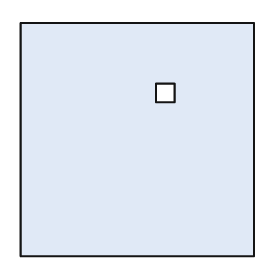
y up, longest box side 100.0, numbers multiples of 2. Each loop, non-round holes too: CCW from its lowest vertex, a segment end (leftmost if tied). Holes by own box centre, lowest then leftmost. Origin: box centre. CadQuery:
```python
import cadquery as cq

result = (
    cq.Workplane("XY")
    .moveTo(-50.0, -50.0)
    .lineTo(50.0, -50.0)
    .lineTo(50.0, 50.0)
    .lineTo(-50.0, 50.0)
    .close()
    .moveTo(8.0, 16.0)
    .lineTo(16.0, 16.0)
    .lineTo(16.0, 24.0)
    .lineTo(8.0, 24.0)
    .close()
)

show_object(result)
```